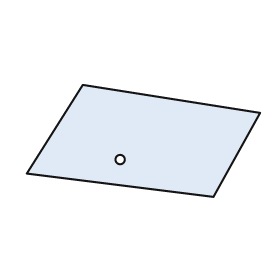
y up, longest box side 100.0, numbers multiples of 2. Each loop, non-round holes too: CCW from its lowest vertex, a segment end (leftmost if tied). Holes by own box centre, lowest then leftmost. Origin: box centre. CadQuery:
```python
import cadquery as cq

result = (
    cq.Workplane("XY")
    .moveTo(30.0, -24.0)
    .lineTo(50.0, 12.0)
    .lineTo(-26.0, 24.0)
    .lineTo(-50.0, -14.0)
    .close()
    .moveTo(-10.0, -8.0)
    .circle(2.0)
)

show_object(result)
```